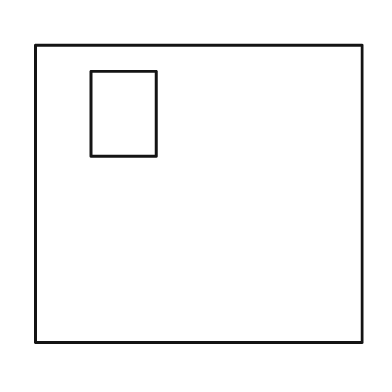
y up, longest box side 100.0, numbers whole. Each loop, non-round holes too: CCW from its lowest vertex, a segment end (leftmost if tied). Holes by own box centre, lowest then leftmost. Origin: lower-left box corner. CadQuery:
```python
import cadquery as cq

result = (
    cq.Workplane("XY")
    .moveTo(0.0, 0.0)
    .lineTo(100.0, 0.0)
    .lineTo(100.0, 91.0)
    .lineTo(0.0, 91.0)
    .close()
    .moveTo(17.0, 57.0)
    .lineTo(37.0, 57.0)
    .lineTo(37.0, 83.0)
    .lineTo(17.0, 83.0)
    .close()
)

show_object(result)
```